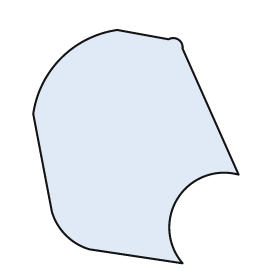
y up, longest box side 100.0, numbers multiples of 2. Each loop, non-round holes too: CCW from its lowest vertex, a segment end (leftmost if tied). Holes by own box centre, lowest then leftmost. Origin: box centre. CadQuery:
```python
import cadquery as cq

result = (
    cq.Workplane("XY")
    .moveTo(20.0, -50.0)
    .threePointArc((18.0, -22.0), (44.0, -12.0))
    .lineTo(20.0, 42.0)
    .threePointArc((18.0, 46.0), (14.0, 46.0))
    .lineTo(-8.0, 50.0)
    .threePointArc((-32.0, 38.0), (-44.0, 14.0))
    .lineTo(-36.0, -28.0)
    .threePointArc((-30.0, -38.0), (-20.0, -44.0))
    .close()
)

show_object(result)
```